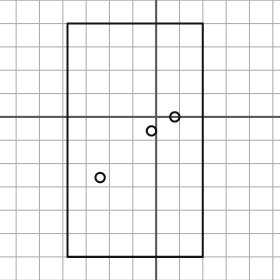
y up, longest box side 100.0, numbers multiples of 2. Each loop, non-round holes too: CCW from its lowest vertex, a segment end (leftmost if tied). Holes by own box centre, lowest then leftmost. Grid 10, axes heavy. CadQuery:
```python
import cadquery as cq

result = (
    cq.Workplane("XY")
    .moveTo(-38.0, -60.0)
    .lineTo(20.0, -60.0)
    .lineTo(20.0, 40.0)
    .lineTo(-38.0, 40.0)
    .close()
    .moveTo(-24.0, -26.0)
    .circle(2.0)
    .moveTo(-2.0, -6.0)
    .circle(2.0)
    .moveTo(8.0, 0.0)
    .circle(2.0)
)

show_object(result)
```